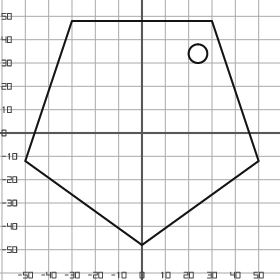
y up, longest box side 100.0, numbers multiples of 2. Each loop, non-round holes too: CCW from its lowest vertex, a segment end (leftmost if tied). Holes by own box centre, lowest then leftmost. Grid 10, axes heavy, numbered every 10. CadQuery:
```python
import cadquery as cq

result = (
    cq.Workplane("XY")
    .moveTo(0.0, -48.0)
    .lineTo(50.0, -12.0)
    .lineTo(30.0, 48.0)
    .lineTo(-30.0, 48.0)
    .lineTo(-50.0, -12.0)
    .close()
    .moveTo(24.0, 34.0)
    .circle(4.0)
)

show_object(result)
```